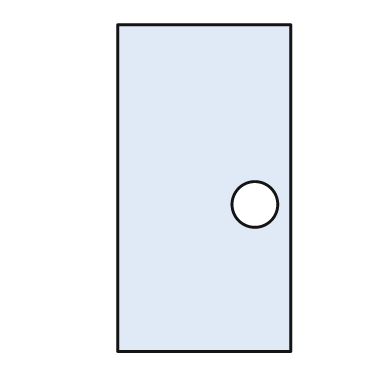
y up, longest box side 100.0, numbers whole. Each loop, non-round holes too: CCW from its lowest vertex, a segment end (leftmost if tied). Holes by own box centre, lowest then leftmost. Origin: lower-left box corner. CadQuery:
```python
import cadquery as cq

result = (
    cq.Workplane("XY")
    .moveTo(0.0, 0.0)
    .lineTo(53.0, 0.0)
    .lineTo(53.0, 100.0)
    .lineTo(0.0, 100.0)
    .close()
    .moveTo(42.0, 45.0)
    .circle(7.0)
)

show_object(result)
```